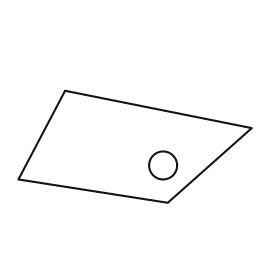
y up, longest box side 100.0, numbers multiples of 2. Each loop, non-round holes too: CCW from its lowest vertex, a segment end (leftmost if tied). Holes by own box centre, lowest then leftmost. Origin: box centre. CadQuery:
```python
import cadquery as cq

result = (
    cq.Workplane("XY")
    .moveTo(14.0, -24.0)
    .lineTo(50.0, 8.0)
    .lineTo(-30.0, 24.0)
    .lineTo(-50.0, -14.0)
    .close()
    .moveTo(12.0, -8.0)
    .circle(6.0)
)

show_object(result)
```